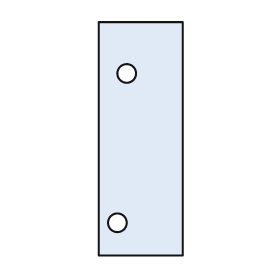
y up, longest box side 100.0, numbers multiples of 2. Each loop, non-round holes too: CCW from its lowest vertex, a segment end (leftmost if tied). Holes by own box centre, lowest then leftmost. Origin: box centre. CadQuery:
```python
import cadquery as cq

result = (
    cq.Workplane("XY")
    .moveTo(-18.0, -50.0)
    .lineTo(18.0, -50.0)
    .lineTo(18.0, 50.0)
    .lineTo(-18.0, 50.0)
    .close()
    .moveTo(-10.0, -36.0)
    .circle(4.0)
    .moveTo(-6.0, 28.0)
    .circle(4.0)
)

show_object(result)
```